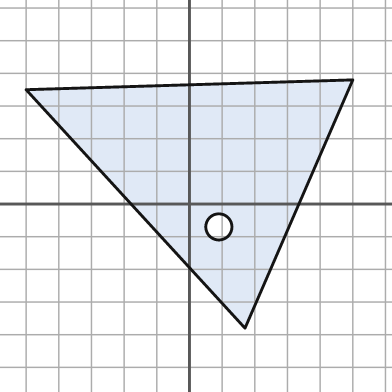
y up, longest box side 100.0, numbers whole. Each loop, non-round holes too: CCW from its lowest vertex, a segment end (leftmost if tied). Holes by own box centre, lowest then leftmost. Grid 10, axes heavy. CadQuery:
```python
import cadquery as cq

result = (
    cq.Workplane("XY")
    .moveTo(17.0, -38.0)
    .lineTo(50.0, 38.0)
    .lineTo(-50.0, 35.0)
    .close()
    .moveTo(9.0, -7.0)
    .circle(4.0)
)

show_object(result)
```